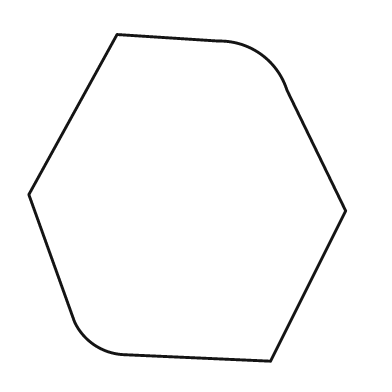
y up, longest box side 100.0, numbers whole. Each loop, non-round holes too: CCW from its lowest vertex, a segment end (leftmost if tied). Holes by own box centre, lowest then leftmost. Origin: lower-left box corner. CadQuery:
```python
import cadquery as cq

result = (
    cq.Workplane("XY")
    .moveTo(74.0, 0.0)
    .lineTo(97.0, 46.0)
    .lineTo(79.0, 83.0)
    .threePointArc((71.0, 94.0), (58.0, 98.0))
    .lineTo(27.0, 100.0)
    .lineTo(0.0, 51.0)
    .lineTo(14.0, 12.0)
    .threePointArc((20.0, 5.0), (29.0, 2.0))
    .close()
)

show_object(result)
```